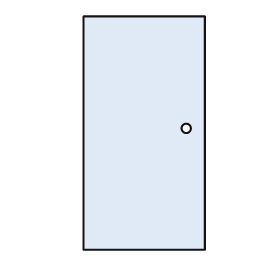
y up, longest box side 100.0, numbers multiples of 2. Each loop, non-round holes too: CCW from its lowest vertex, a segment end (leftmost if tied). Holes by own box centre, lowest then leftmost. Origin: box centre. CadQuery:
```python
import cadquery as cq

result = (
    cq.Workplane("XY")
    .moveTo(-26.0, -50.0)
    .lineTo(26.0, -50.0)
    .lineTo(26.0, 50.0)
    .lineTo(-26.0, 50.0)
    .close()
    .moveTo(18.0, 2.0)
    .circle(2.0)
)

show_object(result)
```